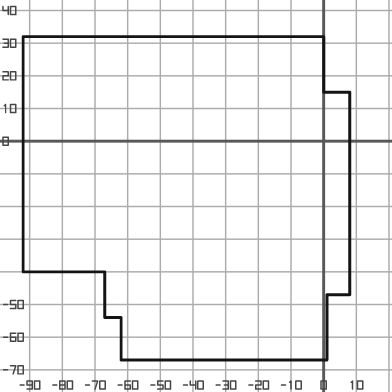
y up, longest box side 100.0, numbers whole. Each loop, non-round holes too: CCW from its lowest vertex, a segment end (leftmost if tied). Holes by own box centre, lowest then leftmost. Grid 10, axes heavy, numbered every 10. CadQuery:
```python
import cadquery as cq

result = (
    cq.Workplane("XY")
    .moveTo(-62.0, -67.0)
    .lineTo(1.0, -67.0)
    .lineTo(1.0, -47.0)
    .lineTo(8.0, -47.0)
    .lineTo(8.0, 15.0)
    .lineTo(0.0, 15.0)
    .lineTo(0.0, 32.0)
    .lineTo(-92.0, 32.0)
    .lineTo(-92.0, -40.0)
    .lineTo(-67.0, -40.0)
    .lineTo(-67.0, -54.0)
    .lineTo(-62.0, -54.0)
    .close()
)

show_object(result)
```